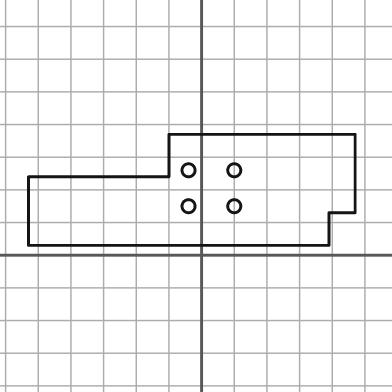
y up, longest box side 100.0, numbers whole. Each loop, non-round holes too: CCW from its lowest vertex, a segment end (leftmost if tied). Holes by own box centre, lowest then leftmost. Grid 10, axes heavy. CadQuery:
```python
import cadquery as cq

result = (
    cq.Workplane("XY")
    .moveTo(-53.0, 3.0)
    .lineTo(39.0, 3.0)
    .lineTo(39.0, 13.0)
    .lineTo(47.0, 13.0)
    .lineTo(47.0, 37.0)
    .lineTo(-10.0, 37.0)
    .lineTo(-10.0, 24.0)
    .lineTo(-53.0, 24.0)
    .close()
    .moveTo(-4.0, 15.0)
    .circle(2.0)
    .moveTo(10.0, 15.0)
    .circle(2.0)
    .moveTo(-4.0, 26.0)
    .circle(2.0)
    .moveTo(10.0, 26.0)
    .circle(2.0)
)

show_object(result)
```